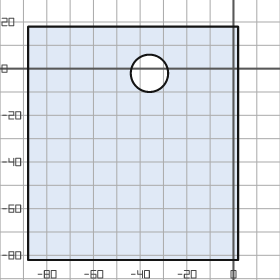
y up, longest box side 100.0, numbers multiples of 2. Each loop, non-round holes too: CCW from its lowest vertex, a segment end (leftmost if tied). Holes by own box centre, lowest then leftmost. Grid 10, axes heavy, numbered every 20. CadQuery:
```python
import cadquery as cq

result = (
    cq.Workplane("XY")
    .moveTo(-88.0, -82.0)
    .lineTo(2.0, -82.0)
    .lineTo(2.0, 18.0)
    .lineTo(-88.0, 18.0)
    .close()
    .moveTo(-36.0, -2.0)
    .circle(8.0)
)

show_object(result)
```